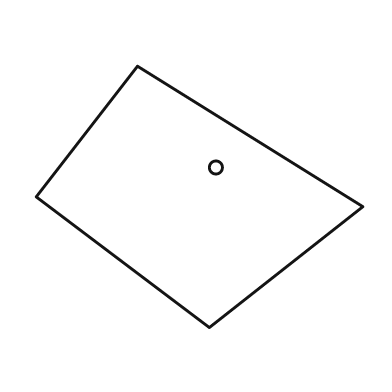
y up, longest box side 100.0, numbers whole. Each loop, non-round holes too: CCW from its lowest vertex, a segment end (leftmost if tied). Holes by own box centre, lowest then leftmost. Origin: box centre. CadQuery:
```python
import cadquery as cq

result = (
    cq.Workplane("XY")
    .moveTo(3.0, -40.0)
    .lineTo(50.0, -3.0)
    .lineTo(-19.0, 40.0)
    .lineTo(-50.0, 0.0)
    .close()
    .moveTo(5.0, 9.0)
    .circle(2.0)
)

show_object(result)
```